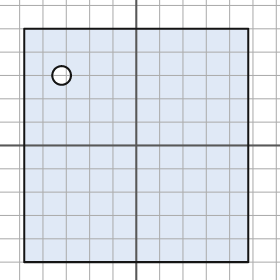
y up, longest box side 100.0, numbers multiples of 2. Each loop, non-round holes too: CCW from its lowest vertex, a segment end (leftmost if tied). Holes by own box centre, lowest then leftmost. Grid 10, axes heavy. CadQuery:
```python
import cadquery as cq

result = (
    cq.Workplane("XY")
    .moveTo(-48.0, -50.0)
    .lineTo(48.0, -50.0)
    .lineTo(48.0, 50.0)
    .lineTo(-48.0, 50.0)
    .close()
    .moveTo(-32.0, 30.0)
    .circle(4.0)
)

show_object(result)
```